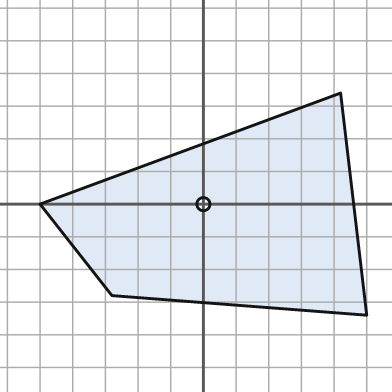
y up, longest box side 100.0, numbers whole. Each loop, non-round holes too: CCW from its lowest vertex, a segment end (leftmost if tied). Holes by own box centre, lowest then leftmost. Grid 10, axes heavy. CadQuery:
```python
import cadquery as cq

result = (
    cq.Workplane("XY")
    .moveTo(50.0, -34.0)
    .lineTo(42.0, 34.0)
    .lineTo(-50.0, 0.0)
    .lineTo(-28.0, -28.0)
    .close()
    .moveTo(0.0, 0.0)
    .circle(2.0)
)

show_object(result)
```